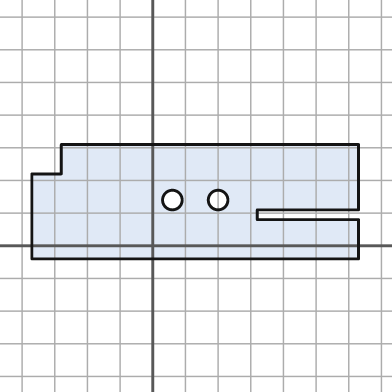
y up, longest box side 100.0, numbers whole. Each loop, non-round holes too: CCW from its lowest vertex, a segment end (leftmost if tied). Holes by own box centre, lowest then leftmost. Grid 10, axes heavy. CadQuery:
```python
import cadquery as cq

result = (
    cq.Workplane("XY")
    .moveTo(-37.0, -4.0)
    .lineTo(63.0, -4.0)
    .lineTo(63.0, 8.0)
    .lineTo(32.0, 8.0)
    .lineTo(32.0, 11.0)
    .lineTo(63.0, 11.0)
    .lineTo(63.0, 31.0)
    .lineTo(-28.0, 31.0)
    .lineTo(-28.0, 22.0)
    .lineTo(-37.0, 22.0)
    .close()
    .moveTo(6.0, 14.0)
    .circle(3.0)
    .moveTo(20.0, 14.0)
    .circle(3.0)
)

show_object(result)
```